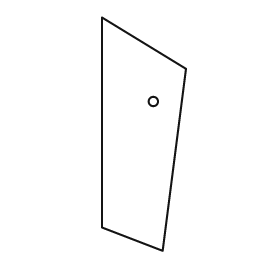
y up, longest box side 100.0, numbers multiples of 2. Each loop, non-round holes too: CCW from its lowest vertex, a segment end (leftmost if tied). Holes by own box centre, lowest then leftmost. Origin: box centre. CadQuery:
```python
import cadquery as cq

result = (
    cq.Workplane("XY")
    .moveTo(8.0, -50.0)
    .lineTo(18.0, 28.0)
    .lineTo(-18.0, 50.0)
    .lineTo(-18.0, -40.0)
    .close()
    .moveTo(4.0, 14.0)
    .circle(2.0)
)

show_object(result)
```